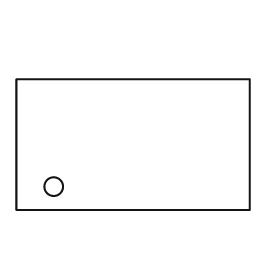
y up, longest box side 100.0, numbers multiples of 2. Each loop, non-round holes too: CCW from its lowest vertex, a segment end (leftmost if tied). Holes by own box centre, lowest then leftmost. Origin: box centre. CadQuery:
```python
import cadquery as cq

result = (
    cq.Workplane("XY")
    .moveTo(-50.0, -28.0)
    .lineTo(50.0, -28.0)
    .lineTo(50.0, 28.0)
    .lineTo(-50.0, 28.0)
    .close()
    .moveTo(-34.0, -18.0)
    .circle(4.0)
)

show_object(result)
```